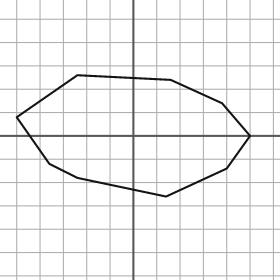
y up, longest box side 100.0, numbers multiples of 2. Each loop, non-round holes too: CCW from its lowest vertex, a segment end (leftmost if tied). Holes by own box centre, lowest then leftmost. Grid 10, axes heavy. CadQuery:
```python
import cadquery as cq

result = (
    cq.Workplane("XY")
    .moveTo(14.0, -26.0)
    .lineTo(40.0, -14.0)
    .lineTo(50.0, 0.0)
    .lineTo(38.0, 14.0)
    .lineTo(16.0, 24.0)
    .lineTo(-24.0, 26.0)
    .lineTo(-50.0, 8.0)
    .lineTo(-36.0, -12.0)
    .lineTo(-24.0, -18.0)
    .close()
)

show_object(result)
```